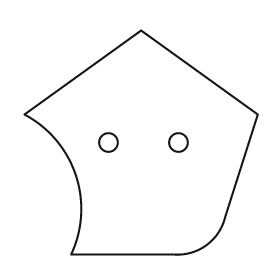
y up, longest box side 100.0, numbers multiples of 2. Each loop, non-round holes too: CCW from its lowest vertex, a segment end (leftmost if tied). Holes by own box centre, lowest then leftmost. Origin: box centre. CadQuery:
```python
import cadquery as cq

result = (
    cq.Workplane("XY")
    .moveTo(-30.0, -48.0)
    .lineTo(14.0, -48.0)
    .threePointArc((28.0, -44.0), (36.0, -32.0))
    .lineTo(50.0, 12.0)
    .lineTo(0.0, 48.0)
    .lineTo(-50.0, 12.0)
    .threePointArc((-28.0, -14.0), (-30.0, -48.0))
    .close()
    .moveTo(-14.0, 0.0)
    .circle(4.0)
    .moveTo(16.0, 0.0)
    .circle(4.0)
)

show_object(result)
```